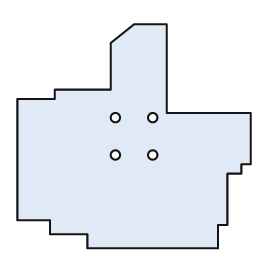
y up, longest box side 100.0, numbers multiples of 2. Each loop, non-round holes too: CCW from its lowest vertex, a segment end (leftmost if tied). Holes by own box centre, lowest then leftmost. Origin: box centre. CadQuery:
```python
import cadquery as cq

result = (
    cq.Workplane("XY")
    .moveTo(-20.0, -48.0)
    .lineTo(36.0, -48.0)
    .lineTo(36.0, -38.0)
    .lineTo(40.0, -38.0)
    .lineTo(40.0, -16.0)
    .lineTo(46.0, -16.0)
    .lineTo(46.0, -12.0)
    .lineTo(50.0, -12.0)
    .lineTo(50.0, 10.0)
    .lineTo(14.0, 10.0)
    .lineTo(14.0, 48.0)
    .lineTo(0.0, 48.0)
    .lineTo(-10.0, 40.0)
    .lineTo(-10.0, 20.0)
    .lineTo(-34.0, 20.0)
    .lineTo(-34.0, 16.0)
    .lineTo(-50.0, 16.0)
    .lineTo(-50.0, -36.0)
    .lineTo(-36.0, -36.0)
    .lineTo(-36.0, -42.0)
    .lineTo(-20.0, -42.0)
    .close()
    .moveTo(-8.0, -8.0)
    .circle(2.0)
    .moveTo(8.0, -8.0)
    .circle(2.0)
    .moveTo(-8.0, 8.0)
    .circle(2.0)
    .moveTo(8.0, 8.0)
    .circle(2.0)
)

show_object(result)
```